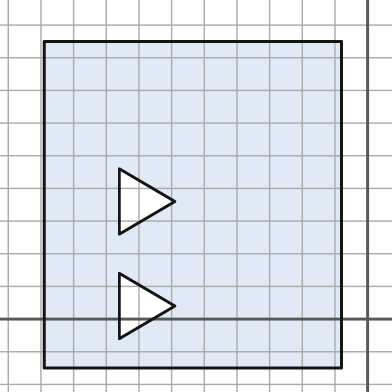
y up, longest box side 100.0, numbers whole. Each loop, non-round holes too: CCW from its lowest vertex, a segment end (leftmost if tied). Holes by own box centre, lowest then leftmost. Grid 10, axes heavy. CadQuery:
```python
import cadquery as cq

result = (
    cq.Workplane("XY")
    .moveTo(-99.0, -15.0)
    .lineTo(-8.0, -15.0)
    .lineTo(-8.0, 85.0)
    .lineTo(-99.0, 85.0)
    .close()
    .moveTo(-76.0, -6.0)
    .lineTo(-59.0, 4.0)
    .lineTo(-76.0, 14.0)
    .close()
    .moveTo(-76.0, 26.0)
    .lineTo(-59.0, 36.0)
    .lineTo(-76.0, 46.0)
    .close()
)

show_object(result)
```